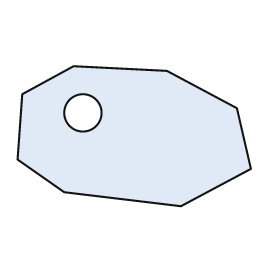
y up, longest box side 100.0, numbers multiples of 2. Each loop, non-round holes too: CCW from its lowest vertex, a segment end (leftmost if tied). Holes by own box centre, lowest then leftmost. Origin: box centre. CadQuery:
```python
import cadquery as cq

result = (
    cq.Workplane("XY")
    .moveTo(20.0, -30.0)
    .lineTo(50.0, -14.0)
    .lineTo(44.0, 12.0)
    .lineTo(14.0, 28.0)
    .lineTo(-26.0, 30.0)
    .lineTo(-48.0, 18.0)
    .lineTo(-50.0, -10.0)
    .lineTo(-30.0, -24.0)
    .close()
    .moveTo(-22.0, 10.0)
    .circle(8.0)
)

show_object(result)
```